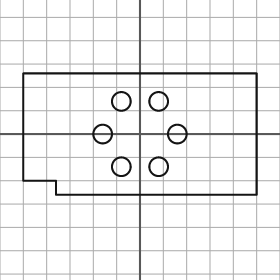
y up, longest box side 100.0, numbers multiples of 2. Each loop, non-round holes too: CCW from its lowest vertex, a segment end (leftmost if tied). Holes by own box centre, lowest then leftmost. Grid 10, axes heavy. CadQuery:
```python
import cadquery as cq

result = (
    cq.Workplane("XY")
    .moveTo(-36.0, -26.0)
    .lineTo(50.0, -26.0)
    .lineTo(50.0, 26.0)
    .lineTo(-50.0, 26.0)
    .lineTo(-50.0, -20.0)
    .lineTo(-36.0, -20.0)
    .close()
    .moveTo(-8.0, -14.0)
    .circle(4.0)
    .moveTo(8.0, -14.0)
    .circle(4.0)
    .moveTo(-16.0, 0.0)
    .circle(4.0)
    .moveTo(16.0, 0.0)
    .circle(4.0)
    .moveTo(-8.0, 14.0)
    .circle(4.0)
    .moveTo(8.0, 14.0)
    .circle(4.0)
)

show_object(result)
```